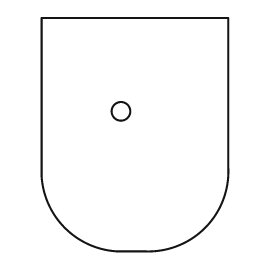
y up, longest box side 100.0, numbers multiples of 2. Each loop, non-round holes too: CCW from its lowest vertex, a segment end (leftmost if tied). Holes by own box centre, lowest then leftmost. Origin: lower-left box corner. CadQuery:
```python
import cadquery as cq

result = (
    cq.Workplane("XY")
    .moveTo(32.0, 0.0)
    .lineTo(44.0, 0.0)
    .threePointArc((70.0, 10.0), (80.0, 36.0))
    .lineTo(80.0, 100.0)
    .lineTo(0.0, 100.0)
    .lineTo(0.0, 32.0)
    .threePointArc((10.0, 10.0), (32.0, 0.0))
    .close()
    .moveTo(34.0, 60.0)
    .circle(4.0)
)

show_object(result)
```